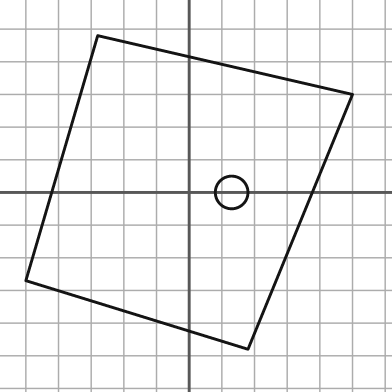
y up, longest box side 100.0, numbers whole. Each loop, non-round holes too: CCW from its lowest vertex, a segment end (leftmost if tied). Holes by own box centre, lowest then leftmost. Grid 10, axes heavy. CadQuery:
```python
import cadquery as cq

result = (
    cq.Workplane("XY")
    .moveTo(18.0, -48.0)
    .lineTo(50.0, 30.0)
    .lineTo(-28.0, 48.0)
    .lineTo(-50.0, -27.0)
    .close()
    .moveTo(13.0, 0.0)
    .circle(5.0)
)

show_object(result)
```